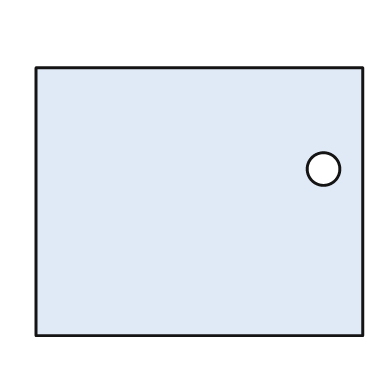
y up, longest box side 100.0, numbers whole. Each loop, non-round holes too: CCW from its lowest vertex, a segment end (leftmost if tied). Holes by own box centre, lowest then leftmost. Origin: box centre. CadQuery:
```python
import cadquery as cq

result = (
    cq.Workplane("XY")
    .moveTo(-50.0, -41.0)
    .lineTo(50.0, -41.0)
    .lineTo(50.0, 41.0)
    .lineTo(-50.0, 41.0)
    .close()
    .moveTo(38.0, 10.0)
    .circle(5.0)
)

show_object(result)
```